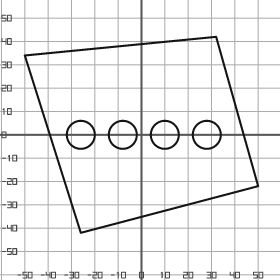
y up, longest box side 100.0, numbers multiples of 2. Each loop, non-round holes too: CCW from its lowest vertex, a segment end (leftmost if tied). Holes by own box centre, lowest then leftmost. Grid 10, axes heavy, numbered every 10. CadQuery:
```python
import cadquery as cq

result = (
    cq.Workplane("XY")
    .moveTo(-26.0, -42.0)
    .lineTo(50.0, -22.0)
    .lineTo(32.0, 42.0)
    .lineTo(-50.0, 34.0)
    .close()
    .moveTo(-26.0, 0.0)
    .circle(6.0)
    .moveTo(-8.0, 0.0)
    .circle(6.0)
    .moveTo(10.0, 0.0)
    .circle(6.0)
    .moveTo(28.0, 0.0)
    .circle(6.0)
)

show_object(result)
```